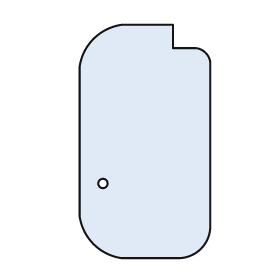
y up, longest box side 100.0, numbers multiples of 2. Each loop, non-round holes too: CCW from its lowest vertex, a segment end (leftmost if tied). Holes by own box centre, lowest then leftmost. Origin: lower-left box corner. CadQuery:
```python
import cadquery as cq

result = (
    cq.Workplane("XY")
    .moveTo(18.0, 0.0)
    .lineTo(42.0, 0.0)
    .threePointArc((52.0, 4.0), (56.0, 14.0))
    .lineTo(56.0, 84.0)
    .threePointArc((54.0, 88.0), (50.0, 90.0))
    .lineTo(40.0, 90.0)
    .lineTo(40.0, 100.0)
    .lineTo(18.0, 100.0)
    .threePointArc((6.0, 94.0), (0.0, 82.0))
    .lineTo(0.0, 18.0)
    .threePointArc((6.0, 6.0), (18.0, 0.0))
    .close()
    .moveTo(10.0, 32.0)
    .circle(2.0)
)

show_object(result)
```